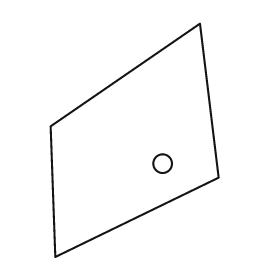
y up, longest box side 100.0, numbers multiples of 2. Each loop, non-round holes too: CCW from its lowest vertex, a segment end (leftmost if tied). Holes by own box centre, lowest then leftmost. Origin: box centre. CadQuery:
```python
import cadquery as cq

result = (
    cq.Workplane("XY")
    .moveTo(-34.0, -50.0)
    .lineTo(36.0, -16.0)
    .lineTo(28.0, 50.0)
    .lineTo(-36.0, 6.0)
    .close()
    .moveTo(12.0, -10.0)
    .circle(4.0)
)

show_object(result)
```